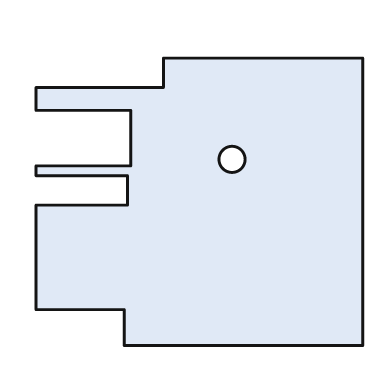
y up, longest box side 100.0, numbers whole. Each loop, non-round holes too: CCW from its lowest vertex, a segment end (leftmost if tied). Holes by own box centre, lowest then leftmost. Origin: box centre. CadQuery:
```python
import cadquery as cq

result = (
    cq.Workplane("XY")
    .moveTo(-23.0, -44.0)
    .lineTo(50.0, -44.0)
    .lineTo(50.0, 44.0)
    .lineTo(-11.0, 44.0)
    .lineTo(-11.0, 35.0)
    .lineTo(-50.0, 35.0)
    .lineTo(-50.0, 28.0)
    .lineTo(-21.0, 28.0)
    .lineTo(-21.0, 11.0)
    .lineTo(-50.0, 11.0)
    .lineTo(-50.0, 8.0)
    .lineTo(-22.0, 8.0)
    .lineTo(-22.0, -1.0)
    .lineTo(-50.0, -1.0)
    .lineTo(-50.0, -33.0)
    .lineTo(-23.0, -33.0)
    .close()
    .moveTo(10.0, 13.0)
    .circle(4.0)
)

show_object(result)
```